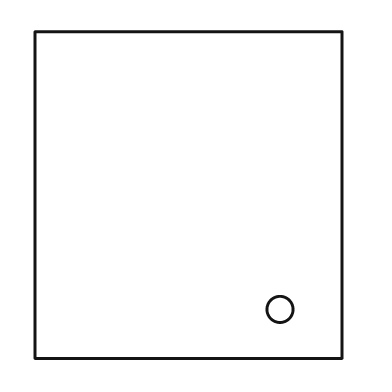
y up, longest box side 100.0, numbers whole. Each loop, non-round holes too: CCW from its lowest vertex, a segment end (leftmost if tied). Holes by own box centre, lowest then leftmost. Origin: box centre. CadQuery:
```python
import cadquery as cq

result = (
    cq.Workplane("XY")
    .moveTo(-47.0, -50.0)
    .lineTo(47.0, -50.0)
    .lineTo(47.0, 50.0)
    .lineTo(-47.0, 50.0)
    .close()
    .moveTo(28.0, -35.0)
    .circle(4.0)
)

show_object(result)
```